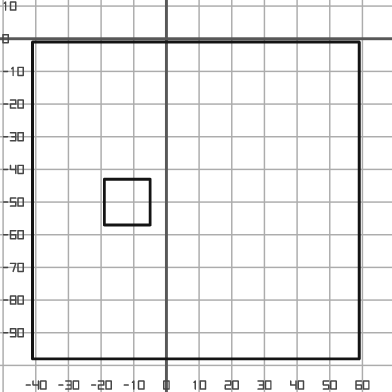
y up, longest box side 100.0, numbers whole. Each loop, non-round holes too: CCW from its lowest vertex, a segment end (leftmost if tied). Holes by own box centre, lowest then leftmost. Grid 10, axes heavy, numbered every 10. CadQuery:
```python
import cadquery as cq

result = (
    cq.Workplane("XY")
    .moveTo(-41.0, -98.0)
    .lineTo(59.0, -98.0)
    .lineTo(59.0, -1.0)
    .lineTo(-41.0, -1.0)
    .close()
    .moveTo(-19.0, -57.0)
    .lineTo(-5.0, -57.0)
    .lineTo(-5.0, -43.0)
    .lineTo(-19.0, -43.0)
    .close()
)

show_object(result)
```